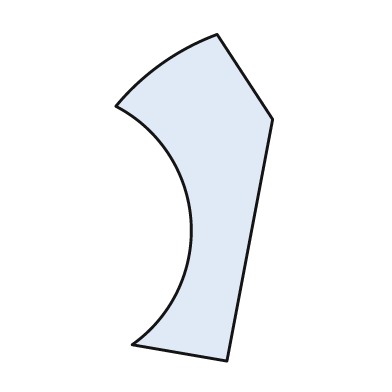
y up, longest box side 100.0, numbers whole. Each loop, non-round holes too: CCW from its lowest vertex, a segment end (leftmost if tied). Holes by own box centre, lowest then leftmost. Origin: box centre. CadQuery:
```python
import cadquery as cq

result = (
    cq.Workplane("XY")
    .moveTo(10.0, -50.0)
    .lineTo(24.0, 24.0)
    .lineTo(7.0, 50.0)
    .threePointArc((-10.0, 41.0), (-24.0, 28.0))
    .threePointArc((-1.0, -7.0), (-19.0, -45.0))
    .close()
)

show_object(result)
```